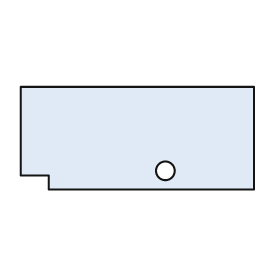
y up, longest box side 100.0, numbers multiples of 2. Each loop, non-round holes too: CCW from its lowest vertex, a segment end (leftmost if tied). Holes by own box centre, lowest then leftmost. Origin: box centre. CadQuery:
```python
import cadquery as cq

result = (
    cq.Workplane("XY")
    .moveTo(-38.0, -22.0)
    .lineTo(50.0, -22.0)
    .lineTo(50.0, 22.0)
    .lineTo(-50.0, 22.0)
    .lineTo(-50.0, -16.0)
    .lineTo(-38.0, -16.0)
    .close()
    .moveTo(12.0, -14.0)
    .circle(4.0)
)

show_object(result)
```